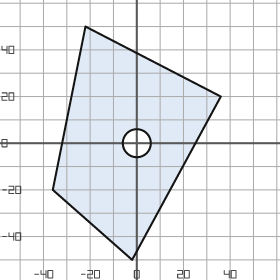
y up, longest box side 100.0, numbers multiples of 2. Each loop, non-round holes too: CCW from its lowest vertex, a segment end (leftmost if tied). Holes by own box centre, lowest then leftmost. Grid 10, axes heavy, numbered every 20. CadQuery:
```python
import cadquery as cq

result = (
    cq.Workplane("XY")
    .moveTo(-2.0, -50.0)
    .lineTo(36.0, 20.0)
    .lineTo(-22.0, 50.0)
    .lineTo(-36.0, -20.0)
    .close()
    .moveTo(0.0, 0.0)
    .circle(6.0)
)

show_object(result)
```